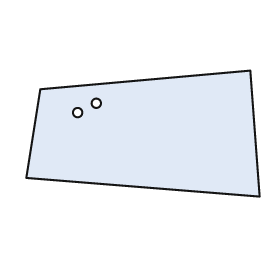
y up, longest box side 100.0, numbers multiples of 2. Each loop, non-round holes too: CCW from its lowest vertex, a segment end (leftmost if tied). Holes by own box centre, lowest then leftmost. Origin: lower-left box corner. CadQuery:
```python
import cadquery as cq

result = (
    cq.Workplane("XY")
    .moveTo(100.0, 0.0)
    .lineTo(96.0, 54.0)
    .lineTo(6.0, 46.0)
    .lineTo(0.0, 8.0)
    .close()
    .moveTo(22.0, 36.0)
    .circle(2.0)
    .moveTo(30.0, 40.0)
    .circle(2.0)
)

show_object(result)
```